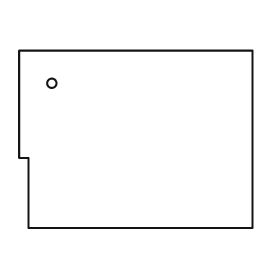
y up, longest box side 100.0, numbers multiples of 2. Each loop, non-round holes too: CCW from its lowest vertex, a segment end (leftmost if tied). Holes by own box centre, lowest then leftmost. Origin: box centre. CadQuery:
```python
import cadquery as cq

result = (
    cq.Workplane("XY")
    .moveTo(-46.0, -38.0)
    .lineTo(50.0, -38.0)
    .lineTo(50.0, 38.0)
    .lineTo(-50.0, 38.0)
    .lineTo(-50.0, -8.0)
    .lineTo(-46.0, -8.0)
    .close()
    .moveTo(-36.0, 24.0)
    .circle(2.0)
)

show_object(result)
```